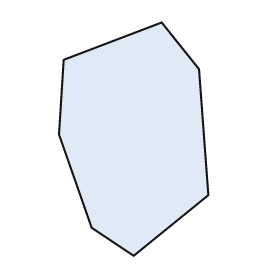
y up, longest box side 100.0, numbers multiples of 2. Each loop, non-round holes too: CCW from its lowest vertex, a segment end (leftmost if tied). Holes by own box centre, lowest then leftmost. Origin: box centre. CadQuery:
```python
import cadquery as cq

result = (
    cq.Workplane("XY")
    .moveTo(0.0, -50.0)
    .lineTo(32.0, -24.0)
    .lineTo(28.0, 30.0)
    .lineTo(12.0, 50.0)
    .lineTo(-30.0, 34.0)
    .lineTo(-32.0, 2.0)
    .lineTo(-18.0, -38.0)
    .close()
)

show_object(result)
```